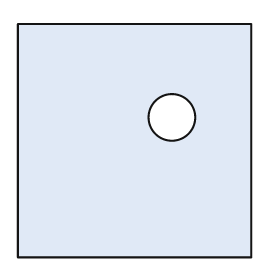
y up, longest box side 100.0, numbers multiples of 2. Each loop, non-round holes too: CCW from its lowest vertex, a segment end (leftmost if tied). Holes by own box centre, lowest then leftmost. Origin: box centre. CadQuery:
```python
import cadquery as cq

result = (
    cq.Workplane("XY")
    .moveTo(-50.0, -50.0)
    .lineTo(50.0, -50.0)
    .lineTo(50.0, 50.0)
    .lineTo(-50.0, 50.0)
    .close()
    .moveTo(16.0, 10.0)
    .circle(10.0)
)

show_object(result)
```